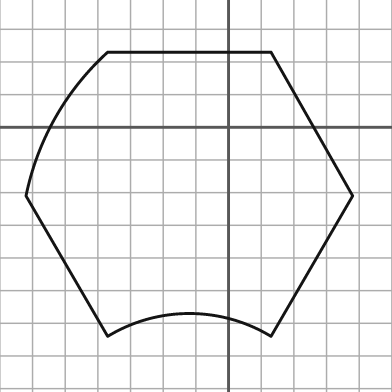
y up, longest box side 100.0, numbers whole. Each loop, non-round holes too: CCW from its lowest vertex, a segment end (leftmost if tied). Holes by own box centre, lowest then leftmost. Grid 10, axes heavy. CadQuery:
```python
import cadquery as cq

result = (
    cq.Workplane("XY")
    .moveTo(-37.0, -64.0)
    .threePointArc((-12.0, -57.0), (13.0, -64.0))
    .lineTo(38.0, -21.0)
    .lineTo(13.0, 23.0)
    .lineTo(-37.0, 23.0)
    .threePointArc((-53.0, 3.0), (-62.0, -21.0))
    .close()
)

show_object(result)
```